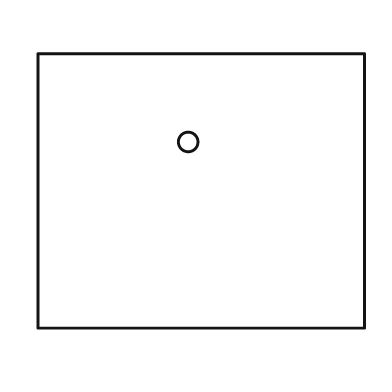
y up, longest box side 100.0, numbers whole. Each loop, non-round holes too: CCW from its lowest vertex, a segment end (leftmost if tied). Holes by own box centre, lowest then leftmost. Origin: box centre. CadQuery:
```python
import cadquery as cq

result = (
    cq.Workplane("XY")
    .moveTo(-50.0, -42.0)
    .lineTo(50.0, -42.0)
    .lineTo(50.0, 42.0)
    .lineTo(-50.0, 42.0)
    .close()
    .moveTo(-4.0, 15.0)
    .circle(3.0)
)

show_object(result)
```